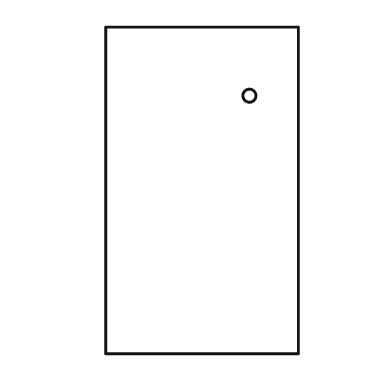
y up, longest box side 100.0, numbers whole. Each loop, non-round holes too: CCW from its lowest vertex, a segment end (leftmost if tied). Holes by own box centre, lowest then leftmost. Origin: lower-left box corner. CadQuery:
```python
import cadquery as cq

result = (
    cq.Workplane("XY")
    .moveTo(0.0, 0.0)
    .lineTo(59.0, 0.0)
    .lineTo(59.0, 100.0)
    .lineTo(0.0, 100.0)
    .close()
    .moveTo(44.0, 79.0)
    .circle(2.0)
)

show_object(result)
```